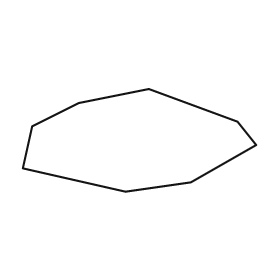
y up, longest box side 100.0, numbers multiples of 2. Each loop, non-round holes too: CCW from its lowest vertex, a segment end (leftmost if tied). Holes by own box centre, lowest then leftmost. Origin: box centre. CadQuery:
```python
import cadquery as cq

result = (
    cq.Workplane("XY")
    .moveTo(-6.0, -22.0)
    .lineTo(22.0, -18.0)
    .lineTo(50.0, -2.0)
    .lineTo(42.0, 8.0)
    .lineTo(4.0, 22.0)
    .lineTo(-26.0, 16.0)
    .lineTo(-46.0, 6.0)
    .lineTo(-50.0, -12.0)
    .close()
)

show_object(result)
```